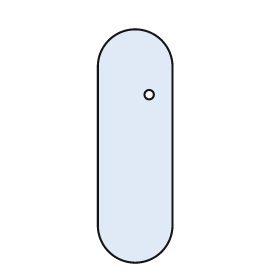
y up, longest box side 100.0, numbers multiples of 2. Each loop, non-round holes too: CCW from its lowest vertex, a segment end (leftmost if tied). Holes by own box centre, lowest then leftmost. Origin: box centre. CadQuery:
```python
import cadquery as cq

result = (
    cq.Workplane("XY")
    .moveTo(-16.0, -34.0)
    .threePointArc((0.0, -50.0), (16.0, -34.0))
    .lineTo(16.0, 34.0)
    .threePointArc((0.0, 50.0), (-16.0, 34.0))
    .close()
    .moveTo(6.0, 22.0)
    .circle(2.0)
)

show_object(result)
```